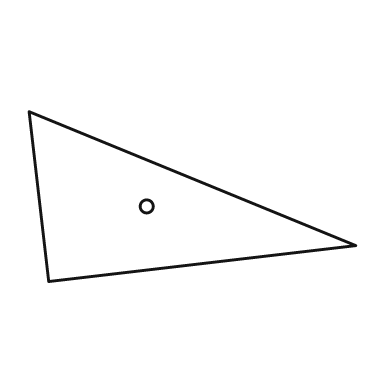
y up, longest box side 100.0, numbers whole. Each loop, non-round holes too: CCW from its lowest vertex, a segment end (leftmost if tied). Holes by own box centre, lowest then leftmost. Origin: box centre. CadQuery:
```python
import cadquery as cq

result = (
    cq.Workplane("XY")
    .moveTo(-44.0, -26.0)
    .lineTo(50.0, -15.0)
    .lineTo(-50.0, 26.0)
    .close()
    .moveTo(-14.0, -3.0)
    .circle(2.0)
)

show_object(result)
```